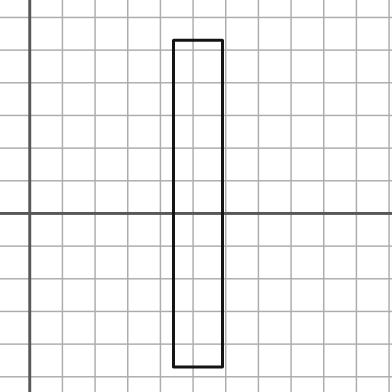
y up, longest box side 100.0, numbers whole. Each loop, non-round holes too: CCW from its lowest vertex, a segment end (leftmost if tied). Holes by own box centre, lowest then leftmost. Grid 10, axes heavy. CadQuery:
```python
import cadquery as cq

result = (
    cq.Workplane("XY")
    .moveTo(44.0, -47.0)
    .lineTo(59.0, -47.0)
    .lineTo(59.0, 53.0)
    .lineTo(44.0, 53.0)
    .close()
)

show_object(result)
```